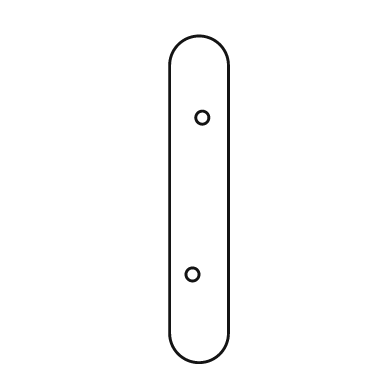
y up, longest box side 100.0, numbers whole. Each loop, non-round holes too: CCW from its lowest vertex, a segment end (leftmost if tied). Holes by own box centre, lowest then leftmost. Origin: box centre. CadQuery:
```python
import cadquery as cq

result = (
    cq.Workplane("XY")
    .moveTo(-9.0, -41.0)
    .threePointArc((0.0, -50.0), (9.0, -41.0))
    .lineTo(9.0, 41.0)
    .threePointArc((0.0, 50.0), (-9.0, 41.0))
    .close()
    .moveTo(-2.0, -23.0)
    .circle(2.0)
    .moveTo(1.0, 25.0)
    .circle(2.0)
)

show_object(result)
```